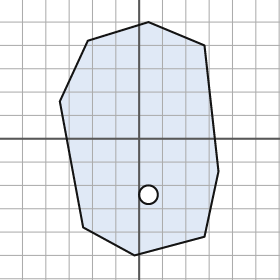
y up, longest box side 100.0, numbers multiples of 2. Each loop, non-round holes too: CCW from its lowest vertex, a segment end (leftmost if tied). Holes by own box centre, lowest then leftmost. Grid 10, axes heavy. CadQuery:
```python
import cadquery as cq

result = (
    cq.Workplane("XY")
    .moveTo(-2.0, -50.0)
    .lineTo(28.0, -42.0)
    .lineTo(34.0, -14.0)
    .lineTo(28.0, 40.0)
    .lineTo(4.0, 50.0)
    .lineTo(-22.0, 42.0)
    .lineTo(-34.0, 16.0)
    .lineTo(-24.0, -38.0)
    .close()
    .moveTo(4.0, -24.0)
    .circle(4.0)
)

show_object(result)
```